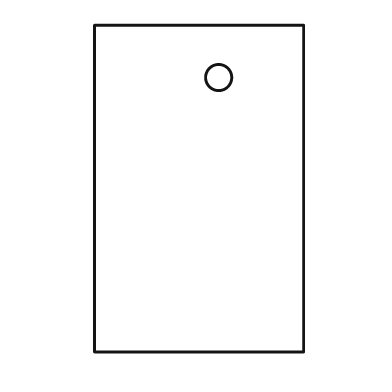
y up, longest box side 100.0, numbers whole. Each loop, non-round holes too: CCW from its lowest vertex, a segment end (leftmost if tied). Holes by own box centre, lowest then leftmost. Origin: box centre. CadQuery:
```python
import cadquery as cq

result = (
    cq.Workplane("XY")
    .moveTo(-32.0, -50.0)
    .lineTo(32.0, -50.0)
    .lineTo(32.0, 50.0)
    .lineTo(-32.0, 50.0)
    .close()
    .moveTo(6.0, 34.0)
    .circle(4.0)
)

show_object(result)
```